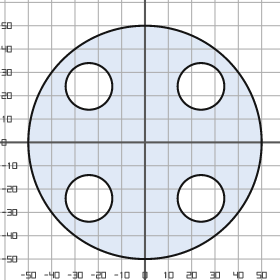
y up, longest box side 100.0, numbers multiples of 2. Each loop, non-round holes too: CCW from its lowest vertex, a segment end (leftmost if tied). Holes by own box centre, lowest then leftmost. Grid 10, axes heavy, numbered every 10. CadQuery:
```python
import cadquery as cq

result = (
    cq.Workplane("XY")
    .moveTo(0.0, 0.0)
    .circle(50.0)
    .moveTo(-24.0, -24.0)
    .circle(10.0)
    .moveTo(24.0, -24.0)
    .circle(10.0)
    .moveTo(-24.0, 24.0)
    .circle(10.0)
    .moveTo(24.0, 24.0)
    .circle(10.0)
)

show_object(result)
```